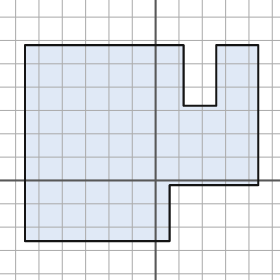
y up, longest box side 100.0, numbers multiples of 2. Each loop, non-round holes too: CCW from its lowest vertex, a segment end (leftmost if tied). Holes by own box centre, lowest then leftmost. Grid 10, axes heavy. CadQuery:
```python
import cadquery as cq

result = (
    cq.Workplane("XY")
    .moveTo(-56.0, -26.0)
    .lineTo(6.0, -26.0)
    .lineTo(6.0, -2.0)
    .lineTo(44.0, -2.0)
    .lineTo(44.0, 58.0)
    .lineTo(26.0, 58.0)
    .lineTo(26.0, 32.0)
    .lineTo(12.0, 32.0)
    .lineTo(12.0, 58.0)
    .lineTo(-56.0, 58.0)
    .close()
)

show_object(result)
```